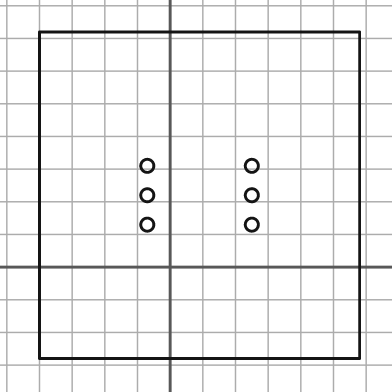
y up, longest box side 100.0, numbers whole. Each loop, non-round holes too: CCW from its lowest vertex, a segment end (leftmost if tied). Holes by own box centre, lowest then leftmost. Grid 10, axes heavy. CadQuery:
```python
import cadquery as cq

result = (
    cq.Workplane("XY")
    .moveTo(-40.0, -28.0)
    .lineTo(58.0, -28.0)
    .lineTo(58.0, 72.0)
    .lineTo(-40.0, 72.0)
    .close()
    .moveTo(-7.0, 13.0)
    .circle(2.0)
    .moveTo(25.0, 13.0)
    .circle(2.0)
    .moveTo(-7.0, 22.0)
    .circle(2.0)
    .moveTo(25.0, 22.0)
    .circle(2.0)
    .moveTo(-7.0, 31.0)
    .circle(2.0)
    .moveTo(25.0, 31.0)
    .circle(2.0)
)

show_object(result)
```